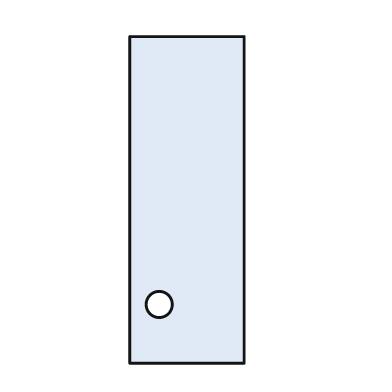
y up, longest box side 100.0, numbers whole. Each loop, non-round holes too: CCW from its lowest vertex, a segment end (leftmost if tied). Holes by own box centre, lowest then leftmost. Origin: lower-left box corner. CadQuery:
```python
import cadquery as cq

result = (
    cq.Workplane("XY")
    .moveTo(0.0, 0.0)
    .lineTo(35.0, 0.0)
    .lineTo(35.0, 100.0)
    .lineTo(0.0, 100.0)
    .close()
    .moveTo(9.0, 18.0)
    .circle(4.0)
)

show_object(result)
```